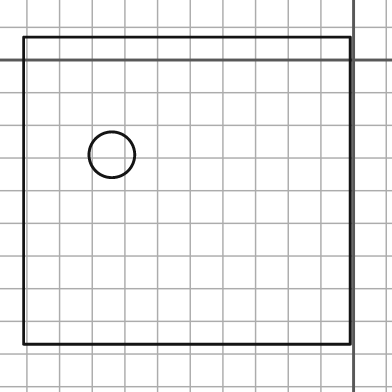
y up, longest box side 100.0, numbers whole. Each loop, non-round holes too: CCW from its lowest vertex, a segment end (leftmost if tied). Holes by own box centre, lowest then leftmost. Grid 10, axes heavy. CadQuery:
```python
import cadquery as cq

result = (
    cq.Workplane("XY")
    .moveTo(-101.0, -87.0)
    .lineTo(-1.0, -87.0)
    .lineTo(-1.0, 7.0)
    .lineTo(-101.0, 7.0)
    .close()
    .moveTo(-74.0, -29.0)
    .circle(7.0)
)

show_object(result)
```